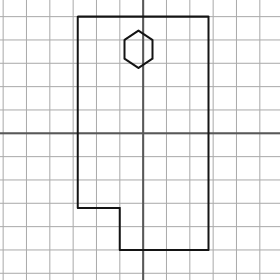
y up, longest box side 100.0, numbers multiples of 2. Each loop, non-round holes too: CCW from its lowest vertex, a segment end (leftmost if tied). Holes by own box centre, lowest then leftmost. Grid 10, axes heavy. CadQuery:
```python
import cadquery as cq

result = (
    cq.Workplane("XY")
    .moveTo(-10.0, -50.0)
    .lineTo(28.0, -50.0)
    .lineTo(28.0, 50.0)
    .lineTo(-28.0, 50.0)
    .lineTo(-28.0, -32.0)
    .lineTo(-10.0, -32.0)
    .close()
    .moveTo(-2.0, 28.0)
    .lineTo(4.0, 32.0)
    .lineTo(4.0, 40.0)
    .lineTo(-2.0, 44.0)
    .lineTo(-8.0, 40.0)
    .lineTo(-8.0, 32.0)
    .close()
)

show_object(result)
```